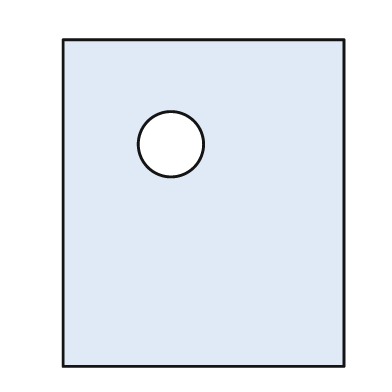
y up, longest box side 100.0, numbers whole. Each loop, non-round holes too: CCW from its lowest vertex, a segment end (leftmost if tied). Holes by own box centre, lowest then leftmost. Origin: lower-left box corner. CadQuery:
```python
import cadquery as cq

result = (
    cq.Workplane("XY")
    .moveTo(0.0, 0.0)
    .lineTo(86.0, 0.0)
    .lineTo(86.0, 100.0)
    .lineTo(0.0, 100.0)
    .close()
    .moveTo(33.0, 68.0)
    .circle(10.0)
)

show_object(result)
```